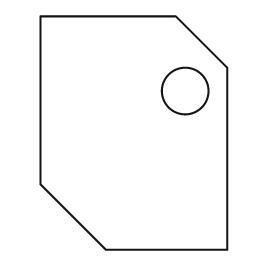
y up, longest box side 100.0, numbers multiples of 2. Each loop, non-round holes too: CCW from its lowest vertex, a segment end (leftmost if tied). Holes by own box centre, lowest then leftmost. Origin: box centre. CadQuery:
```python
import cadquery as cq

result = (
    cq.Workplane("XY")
    .moveTo(-12.0, -50.0)
    .lineTo(40.0, -50.0)
    .lineTo(40.0, 28.0)
    .lineTo(18.0, 50.0)
    .lineTo(-40.0, 50.0)
    .lineTo(-40.0, -22.0)
    .close()
    .moveTo(22.0, 18.0)
    .circle(10.0)
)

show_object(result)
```